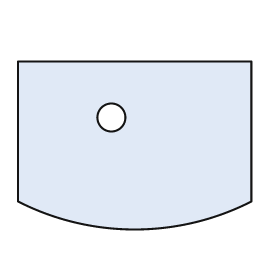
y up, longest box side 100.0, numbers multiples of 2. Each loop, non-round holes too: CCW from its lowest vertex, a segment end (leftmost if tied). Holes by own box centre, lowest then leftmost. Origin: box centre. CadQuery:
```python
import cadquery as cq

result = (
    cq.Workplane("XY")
    .moveTo(-50.0, -24.0)
    .threePointArc((0.0, -36.0), (50.0, -24.0))
    .lineTo(50.0, 36.0)
    .lineTo(-50.0, 36.0)
    .close()
    .moveTo(-10.0, 12.0)
    .circle(6.0)
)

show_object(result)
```